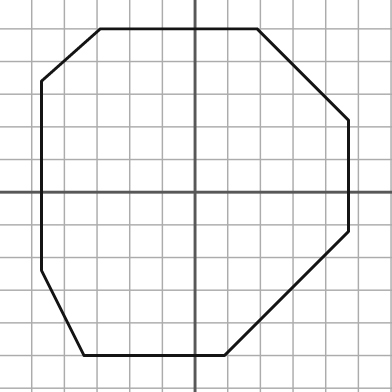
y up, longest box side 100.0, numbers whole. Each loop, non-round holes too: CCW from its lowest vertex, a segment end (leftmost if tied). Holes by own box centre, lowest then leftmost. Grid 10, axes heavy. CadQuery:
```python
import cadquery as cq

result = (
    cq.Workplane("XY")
    .moveTo(-34.0, -50.0)
    .lineTo(9.0, -50.0)
    .lineTo(47.0, -12.0)
    .lineTo(47.0, 22.0)
    .lineTo(19.0, 50.0)
    .lineTo(-29.0, 50.0)
    .lineTo(-47.0, 34.0)
    .lineTo(-47.0, -24.0)
    .close()
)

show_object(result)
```